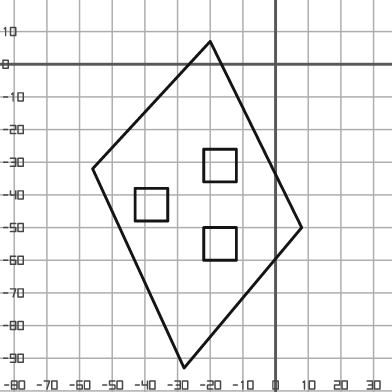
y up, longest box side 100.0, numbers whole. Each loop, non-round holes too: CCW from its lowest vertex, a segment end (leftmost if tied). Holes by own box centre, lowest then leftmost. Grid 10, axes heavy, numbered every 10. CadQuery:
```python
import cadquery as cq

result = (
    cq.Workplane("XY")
    .moveTo(-28.0, -93.0)
    .lineTo(8.0, -50.0)
    .lineTo(-20.0, 7.0)
    .lineTo(-56.0, -32.0)
    .close()
    .moveTo(-22.0, -60.0)
    .lineTo(-12.0, -60.0)
    .lineTo(-12.0, -50.0)
    .lineTo(-22.0, -50.0)
    .close()
    .moveTo(-43.0, -48.0)
    .lineTo(-33.0, -48.0)
    .lineTo(-33.0, -38.0)
    .lineTo(-43.0, -38.0)
    .close()
    .moveTo(-22.0, -36.0)
    .lineTo(-12.0, -36.0)
    .lineTo(-12.0, -26.0)
    .lineTo(-22.0, -26.0)
    .close()
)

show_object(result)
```